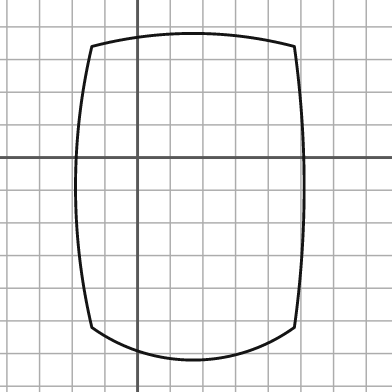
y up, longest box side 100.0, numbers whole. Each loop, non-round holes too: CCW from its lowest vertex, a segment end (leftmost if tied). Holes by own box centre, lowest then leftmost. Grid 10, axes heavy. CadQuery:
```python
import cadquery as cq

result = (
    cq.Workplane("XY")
    .moveTo(-14.0, -52.0)
    .threePointArc((17.0, -62.0), (48.0, -52.0))
    .threePointArc((51.0, -9.0), (48.0, 34.0))
    .threePointArc((17.0, 38.0), (-14.0, 34.0))
    .threePointArc((-19.0, -9.0), (-14.0, -52.0))
    .close()
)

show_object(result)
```